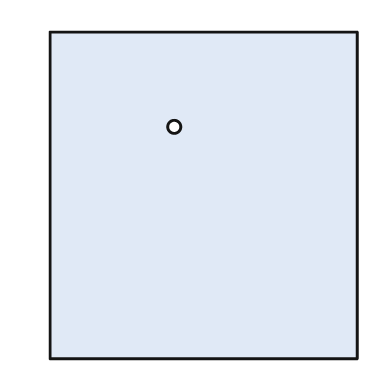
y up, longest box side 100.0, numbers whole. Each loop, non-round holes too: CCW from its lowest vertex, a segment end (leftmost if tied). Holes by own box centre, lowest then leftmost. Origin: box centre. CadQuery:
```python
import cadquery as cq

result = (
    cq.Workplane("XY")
    .moveTo(-47.0, -50.0)
    .lineTo(47.0, -50.0)
    .lineTo(47.0, 50.0)
    .lineTo(-47.0, 50.0)
    .close()
    .moveTo(-9.0, 21.0)
    .circle(2.0)
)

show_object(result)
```